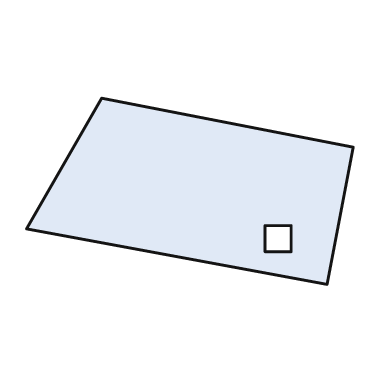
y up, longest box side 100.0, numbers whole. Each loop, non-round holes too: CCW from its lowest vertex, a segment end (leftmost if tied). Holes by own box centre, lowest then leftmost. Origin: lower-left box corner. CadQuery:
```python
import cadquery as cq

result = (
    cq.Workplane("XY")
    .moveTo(92.0, 0.0)
    .lineTo(100.0, 42.0)
    .lineTo(23.0, 57.0)
    .lineTo(0.0, 17.0)
    .close()
    .moveTo(73.0, 10.0)
    .lineTo(81.0, 10.0)
    .lineTo(81.0, 18.0)
    .lineTo(73.0, 18.0)
    .close()
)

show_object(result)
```